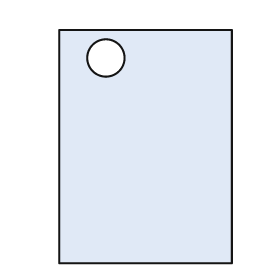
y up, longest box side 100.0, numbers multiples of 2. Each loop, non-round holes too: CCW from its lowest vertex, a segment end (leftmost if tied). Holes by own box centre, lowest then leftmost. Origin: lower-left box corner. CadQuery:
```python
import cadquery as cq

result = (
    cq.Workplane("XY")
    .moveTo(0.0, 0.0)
    .lineTo(74.0, 0.0)
    .lineTo(74.0, 100.0)
    .lineTo(0.0, 100.0)
    .close()
    .moveTo(20.0, 88.0)
    .circle(8.0)
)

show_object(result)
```